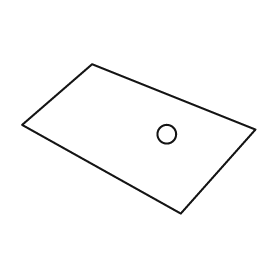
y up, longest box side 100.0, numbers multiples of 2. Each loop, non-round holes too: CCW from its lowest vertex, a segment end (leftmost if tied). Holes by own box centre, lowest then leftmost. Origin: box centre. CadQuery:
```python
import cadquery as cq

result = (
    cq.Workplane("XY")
    .moveTo(18.0, -32.0)
    .lineTo(50.0, 4.0)
    .lineTo(-20.0, 32.0)
    .lineTo(-50.0, 6.0)
    .close()
    .moveTo(12.0, 2.0)
    .circle(4.0)
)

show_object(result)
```